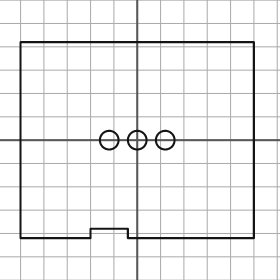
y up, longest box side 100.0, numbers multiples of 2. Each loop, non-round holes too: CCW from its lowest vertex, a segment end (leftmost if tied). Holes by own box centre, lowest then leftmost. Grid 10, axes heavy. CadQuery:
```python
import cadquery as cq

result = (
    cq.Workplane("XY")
    .moveTo(-50.0, -42.0)
    .lineTo(-20.0, -42.0)
    .lineTo(-20.0, -38.0)
    .lineTo(-4.0, -38.0)
    .lineTo(-4.0, -42.0)
    .lineTo(50.0, -42.0)
    .lineTo(50.0, 42.0)
    .lineTo(-50.0, 42.0)
    .close()
    .moveTo(-12.0, 0.0)
    .circle(4.0)
    .moveTo(0.0, 0.0)
    .circle(4.0)
    .moveTo(12.0, 0.0)
    .circle(4.0)
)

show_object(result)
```